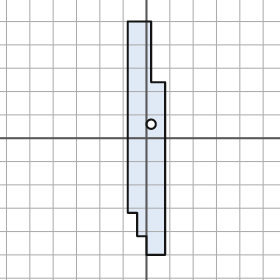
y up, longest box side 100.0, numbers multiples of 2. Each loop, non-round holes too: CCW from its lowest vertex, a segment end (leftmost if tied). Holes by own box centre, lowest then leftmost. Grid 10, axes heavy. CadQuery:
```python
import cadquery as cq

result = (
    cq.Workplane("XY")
    .moveTo(0.0, -50.0)
    .lineTo(8.0, -50.0)
    .lineTo(8.0, 24.0)
    .lineTo(2.0, 24.0)
    .lineTo(2.0, 50.0)
    .lineTo(-8.0, 50.0)
    .lineTo(-8.0, -32.0)
    .lineTo(-4.0, -32.0)
    .lineTo(-4.0, -42.0)
    .lineTo(0.0, -42.0)
    .close()
    .moveTo(2.0, 6.0)
    .circle(2.0)
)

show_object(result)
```